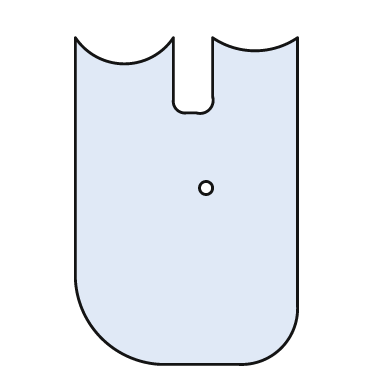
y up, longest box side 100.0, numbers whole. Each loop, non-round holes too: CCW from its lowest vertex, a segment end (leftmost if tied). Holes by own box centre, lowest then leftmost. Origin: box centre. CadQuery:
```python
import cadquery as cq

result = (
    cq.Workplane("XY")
    .moveTo(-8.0, -50.0)
    .lineTo(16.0, -50.0)
    .threePointArc((29.0, -45.0), (34.0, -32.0))
    .lineTo(34.0, 50.0)
    .threePointArc((21.0, 46.0), (8.0, 50.0))
    .lineTo(8.0, 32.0)
    .threePointArc((7.0, 28.0), (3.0, 27.0))
    .lineTo(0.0, 27.0)
    .threePointArc((-3.0, 28.0), (-4.0, 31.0))
    .lineTo(-4.0, 50.0)
    .threePointArc((-19.0, 42.0), (-34.0, 50.0))
    .lineTo(-34.0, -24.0)
    .threePointArc((-26.0, -42.0), (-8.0, -50.0))
    .close()
    .moveTo(6.0, 4.0)
    .circle(2.0)
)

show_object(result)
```